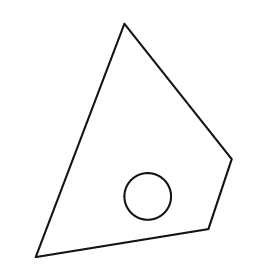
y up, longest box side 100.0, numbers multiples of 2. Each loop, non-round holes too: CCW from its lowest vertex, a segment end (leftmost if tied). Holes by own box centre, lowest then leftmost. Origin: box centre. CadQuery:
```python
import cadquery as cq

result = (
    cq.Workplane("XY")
    .moveTo(-42.0, -50.0)
    .lineTo(32.0, -38.0)
    .lineTo(42.0, -8.0)
    .lineTo(-4.0, 50.0)
    .close()
    .moveTo(6.0, -24.0)
    .circle(10.0)
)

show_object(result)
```